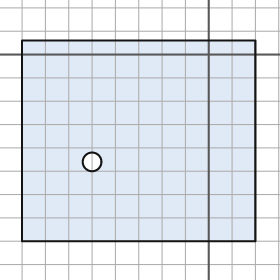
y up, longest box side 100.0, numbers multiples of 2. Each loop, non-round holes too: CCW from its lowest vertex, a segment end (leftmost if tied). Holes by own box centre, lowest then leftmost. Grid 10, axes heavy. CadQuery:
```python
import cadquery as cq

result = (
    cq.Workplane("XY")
    .moveTo(-80.0, -80.0)
    .lineTo(20.0, -80.0)
    .lineTo(20.0, 6.0)
    .lineTo(-80.0, 6.0)
    .close()
    .moveTo(-50.0, -46.0)
    .circle(4.0)
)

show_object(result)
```